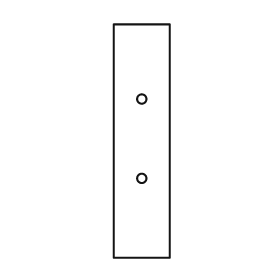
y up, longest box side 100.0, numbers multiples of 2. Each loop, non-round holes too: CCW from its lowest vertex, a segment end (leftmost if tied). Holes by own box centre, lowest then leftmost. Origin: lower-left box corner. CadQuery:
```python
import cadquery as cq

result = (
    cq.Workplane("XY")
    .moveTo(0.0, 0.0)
    .lineTo(24.0, 0.0)
    .lineTo(24.0, 100.0)
    .lineTo(0.0, 100.0)
    .close()
    .moveTo(12.0, 34.0)
    .circle(2.0)
    .moveTo(12.0, 68.0)
    .circle(2.0)
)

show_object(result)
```